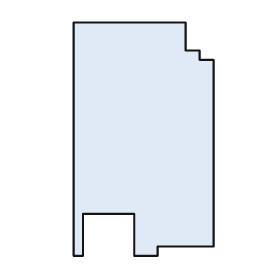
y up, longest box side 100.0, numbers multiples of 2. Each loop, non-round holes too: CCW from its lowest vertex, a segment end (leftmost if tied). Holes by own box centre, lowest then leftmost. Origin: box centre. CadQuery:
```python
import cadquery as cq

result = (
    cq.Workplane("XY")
    .moveTo(-30.0, -50.0)
    .lineTo(-26.0, -50.0)
    .lineTo(-26.0, -32.0)
    .lineTo(-4.0, -32.0)
    .lineTo(-4.0, -50.0)
    .lineTo(6.0, -50.0)
    .lineTo(6.0, -46.0)
    .lineTo(30.0, -46.0)
    .lineTo(30.0, 34.0)
    .lineTo(24.0, 34.0)
    .lineTo(24.0, 38.0)
    .lineTo(18.0, 38.0)
    .lineTo(18.0, 50.0)
    .lineTo(-30.0, 50.0)
    .close()
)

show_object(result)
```